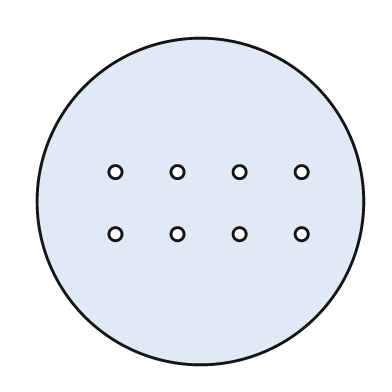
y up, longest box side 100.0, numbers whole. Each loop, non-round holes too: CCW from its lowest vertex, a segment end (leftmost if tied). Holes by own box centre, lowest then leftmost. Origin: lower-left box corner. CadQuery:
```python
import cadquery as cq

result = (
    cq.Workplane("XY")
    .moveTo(50.0, 50.0)
    .circle(50.0)
    .moveTo(24.0, 40.0)
    .circle(2.0)
    .moveTo(43.0, 40.0)
    .circle(2.0)
    .moveTo(62.0, 40.0)
    .circle(2.0)
    .moveTo(81.0, 40.0)
    .circle(2.0)
    .moveTo(24.0, 59.0)
    .circle(2.0)
    .moveTo(43.0, 59.0)
    .circle(2.0)
    .moveTo(62.0, 59.0)
    .circle(2.0)
    .moveTo(81.0, 59.0)
    .circle(2.0)
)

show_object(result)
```